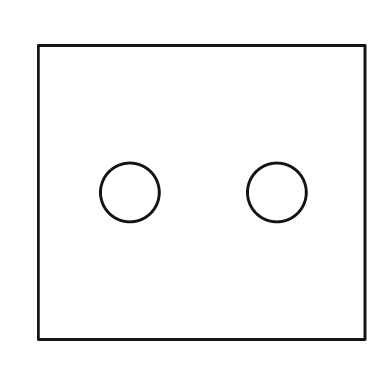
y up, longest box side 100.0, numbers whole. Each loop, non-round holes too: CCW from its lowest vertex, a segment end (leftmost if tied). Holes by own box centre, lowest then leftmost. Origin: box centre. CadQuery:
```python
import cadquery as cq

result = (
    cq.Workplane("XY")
    .moveTo(-50.0, -45.0)
    .lineTo(50.0, -45.0)
    .lineTo(50.0, 45.0)
    .lineTo(-50.0, 45.0)
    .close()
    .moveTo(-22.0, 0.0)
    .circle(9.0)
    .moveTo(23.0, 0.0)
    .circle(9.0)
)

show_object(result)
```